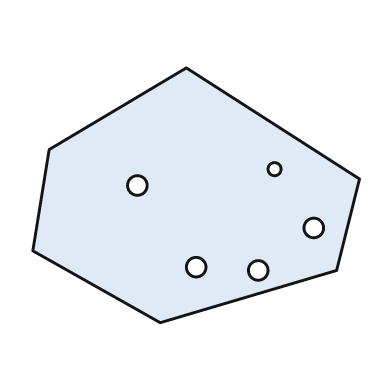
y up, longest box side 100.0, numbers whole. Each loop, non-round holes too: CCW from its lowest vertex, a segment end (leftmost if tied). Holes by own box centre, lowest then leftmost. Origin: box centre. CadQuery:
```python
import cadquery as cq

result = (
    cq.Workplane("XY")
    .moveTo(-11.0, -39.0)
    .lineTo(43.0, -23.0)
    .lineTo(50.0, 5.0)
    .lineTo(-3.0, 39.0)
    .lineTo(-45.0, 14.0)
    .lineTo(-50.0, -17.0)
    .close()
    .moveTo(19.0, -23.0)
    .circle(3.0)
    .moveTo(0.0, -22.0)
    .circle(3.0)
    .moveTo(36.0, -10.0)
    .circle(3.0)
    .moveTo(-18.0, 3.0)
    .circle(3.0)
    .moveTo(24.0, 8.0)
    .circle(2.0)
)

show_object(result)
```